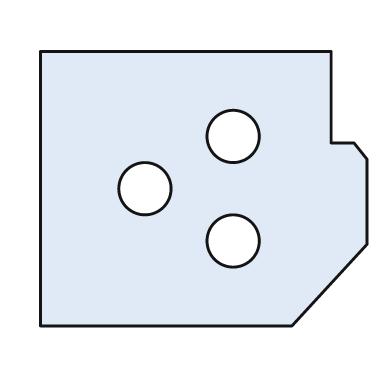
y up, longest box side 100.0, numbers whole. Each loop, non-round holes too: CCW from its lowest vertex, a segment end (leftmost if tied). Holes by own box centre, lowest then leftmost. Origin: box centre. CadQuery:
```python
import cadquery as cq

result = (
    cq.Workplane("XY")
    .moveTo(-50.0, -42.0)
    .lineTo(27.0, -42.0)
    .lineTo(50.0, -17.0)
    .lineTo(50.0, 9.0)
    .lineTo(46.0, 14.0)
    .lineTo(39.0, 14.0)
    .lineTo(39.0, 42.0)
    .lineTo(-50.0, 42.0)
    .close()
    .moveTo(9.0, -16.0)
    .circle(8.0)
    .moveTo(-18.0, 0.0)
    .circle(8.0)
    .moveTo(9.0, 16.0)
    .circle(8.0)
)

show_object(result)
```